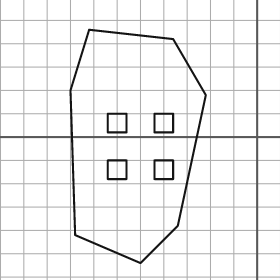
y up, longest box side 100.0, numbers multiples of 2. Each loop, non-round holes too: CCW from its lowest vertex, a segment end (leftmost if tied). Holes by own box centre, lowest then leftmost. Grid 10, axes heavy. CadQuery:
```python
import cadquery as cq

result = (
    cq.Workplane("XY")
    .moveTo(-50.0, -54.0)
    .lineTo(-34.0, -38.0)
    .lineTo(-22.0, 18.0)
    .lineTo(-36.0, 42.0)
    .lineTo(-72.0, 46.0)
    .lineTo(-80.0, 20.0)
    .lineTo(-78.0, -42.0)
    .close()
    .moveTo(-64.0, -18.0)
    .lineTo(-56.0, -18.0)
    .lineTo(-56.0, -10.0)
    .lineTo(-64.0, -10.0)
    .close()
    .moveTo(-44.0, -18.0)
    .lineTo(-36.0, -18.0)
    .lineTo(-36.0, -10.0)
    .lineTo(-44.0, -10.0)
    .close()
    .moveTo(-64.0, 2.0)
    .lineTo(-56.0, 2.0)
    .lineTo(-56.0, 10.0)
    .lineTo(-64.0, 10.0)
    .close()
    .moveTo(-44.0, 2.0)
    .lineTo(-36.0, 2.0)
    .lineTo(-36.0, 10.0)
    .lineTo(-44.0, 10.0)
    .close()
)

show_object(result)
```